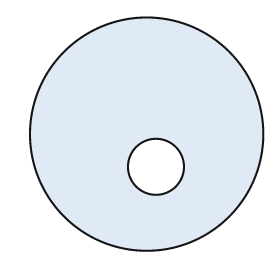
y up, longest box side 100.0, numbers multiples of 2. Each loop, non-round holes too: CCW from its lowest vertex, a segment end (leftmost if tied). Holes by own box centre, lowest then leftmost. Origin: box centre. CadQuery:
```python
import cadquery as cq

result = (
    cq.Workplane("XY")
    .moveTo(0.0, 0.0)
    .circle(50.0)
    .moveTo(4.0, -14.0)
    .circle(12.0)
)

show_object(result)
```